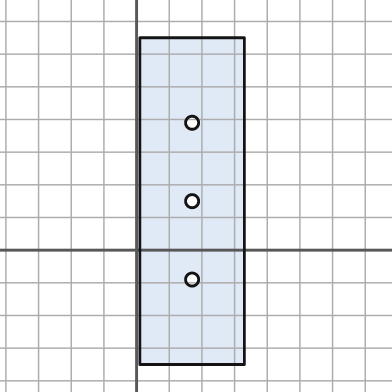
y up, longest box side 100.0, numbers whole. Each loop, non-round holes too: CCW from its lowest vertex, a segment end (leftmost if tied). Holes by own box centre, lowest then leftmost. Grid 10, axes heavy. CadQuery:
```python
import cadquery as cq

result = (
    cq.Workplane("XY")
    .moveTo(1.0, -35.0)
    .lineTo(33.0, -35.0)
    .lineTo(33.0, 65.0)
    .lineTo(1.0, 65.0)
    .close()
    .moveTo(17.0, -9.0)
    .circle(2.0)
    .moveTo(17.0, 15.0)
    .circle(2.0)
    .moveTo(17.0, 39.0)
    .circle(2.0)
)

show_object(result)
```